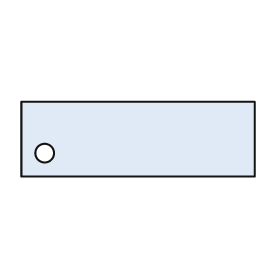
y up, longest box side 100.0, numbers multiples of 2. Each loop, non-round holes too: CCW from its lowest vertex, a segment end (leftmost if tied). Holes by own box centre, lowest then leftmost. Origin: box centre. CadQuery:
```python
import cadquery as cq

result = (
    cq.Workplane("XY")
    .moveTo(-50.0, -16.0)
    .lineTo(50.0, -16.0)
    .lineTo(50.0, 16.0)
    .lineTo(-50.0, 16.0)
    .close()
    .moveTo(-40.0, -6.0)
    .circle(4.0)
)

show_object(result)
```